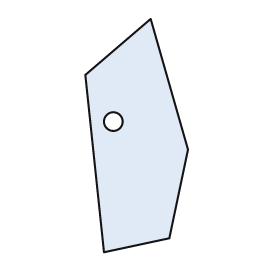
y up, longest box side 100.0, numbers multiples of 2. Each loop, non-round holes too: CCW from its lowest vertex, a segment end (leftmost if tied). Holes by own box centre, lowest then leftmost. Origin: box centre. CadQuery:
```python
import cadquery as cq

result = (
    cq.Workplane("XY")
    .moveTo(-14.0, -50.0)
    .lineTo(14.0, -44.0)
    .lineTo(22.0, -6.0)
    .lineTo(6.0, 50.0)
    .lineTo(-22.0, 26.0)
    .close()
    .moveTo(-10.0, 6.0)
    .circle(4.0)
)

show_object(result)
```